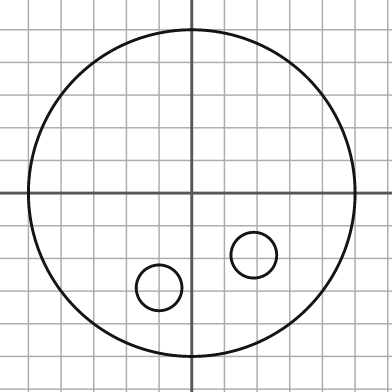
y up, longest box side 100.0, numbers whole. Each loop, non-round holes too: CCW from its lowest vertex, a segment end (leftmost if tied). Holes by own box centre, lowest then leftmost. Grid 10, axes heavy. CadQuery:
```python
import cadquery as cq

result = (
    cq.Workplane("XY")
    .moveTo(0.0, 0.0)
    .circle(50.0)
    .moveTo(-10.0, -29.0)
    .circle(7.0)
    .moveTo(19.0, -19.0)
    .circle(7.0)
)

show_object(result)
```